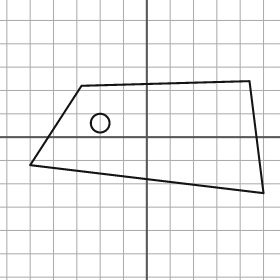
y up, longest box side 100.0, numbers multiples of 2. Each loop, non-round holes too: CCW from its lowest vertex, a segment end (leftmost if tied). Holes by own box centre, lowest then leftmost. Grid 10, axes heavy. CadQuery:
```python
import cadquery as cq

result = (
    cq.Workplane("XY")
    .moveTo(50.0, -24.0)
    .lineTo(44.0, 24.0)
    .lineTo(-28.0, 22.0)
    .lineTo(-50.0, -12.0)
    .close()
    .moveTo(-20.0, 6.0)
    .circle(4.0)
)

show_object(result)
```